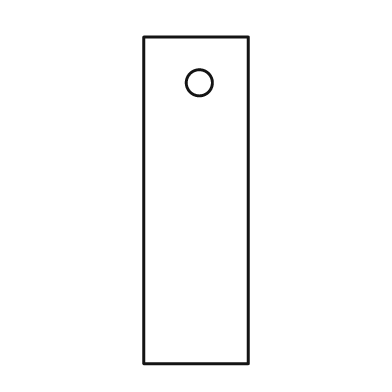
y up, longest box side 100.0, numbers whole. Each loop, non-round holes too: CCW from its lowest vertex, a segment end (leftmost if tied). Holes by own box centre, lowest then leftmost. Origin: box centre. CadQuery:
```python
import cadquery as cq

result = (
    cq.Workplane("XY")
    .moveTo(-16.0, -50.0)
    .lineTo(16.0, -50.0)
    .lineTo(16.0, 50.0)
    .lineTo(-16.0, 50.0)
    .close()
    .moveTo(1.0, 36.0)
    .circle(4.0)
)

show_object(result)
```